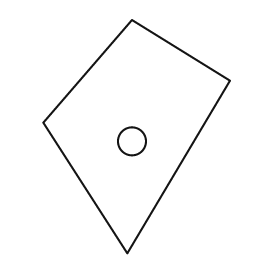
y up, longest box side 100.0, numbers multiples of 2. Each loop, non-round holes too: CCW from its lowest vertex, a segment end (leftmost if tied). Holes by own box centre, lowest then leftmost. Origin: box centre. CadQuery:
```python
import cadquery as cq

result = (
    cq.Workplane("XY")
    .moveTo(-4.0, -50.0)
    .lineTo(40.0, 24.0)
    .lineTo(-2.0, 50.0)
    .lineTo(-40.0, 6.0)
    .close()
    .moveTo(-2.0, -2.0)
    .circle(6.0)
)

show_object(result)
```